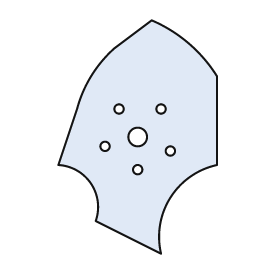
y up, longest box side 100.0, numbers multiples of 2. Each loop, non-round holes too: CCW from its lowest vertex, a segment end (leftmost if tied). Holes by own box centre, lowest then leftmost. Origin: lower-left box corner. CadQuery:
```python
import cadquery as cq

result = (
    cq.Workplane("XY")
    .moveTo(44.0, 0.0)
    .threePointArc((48.0, 24.0), (68.0, 38.0))
    .lineTo(68.0, 76.0)
    .threePointArc((56.0, 90.0), (40.0, 100.0))
    .lineTo(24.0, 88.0)
    .threePointArc((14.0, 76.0), (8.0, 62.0))
    .lineTo(0.0, 38.0)
    .threePointArc((14.0, 30.0), (16.0, 14.0))
    .close()
    .moveTo(34.0, 36.0)
    .circle(2.0)
    .moveTo(48.0, 44.0)
    .circle(2.0)
    .moveTo(20.0, 46.0)
    .circle(2.0)
    .moveTo(34.0, 50.0)
    .circle(4.0)
    .moveTo(26.0, 62.0)
    .circle(2.0)
    .moveTo(44.0, 62.0)
    .circle(2.0)
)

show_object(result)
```